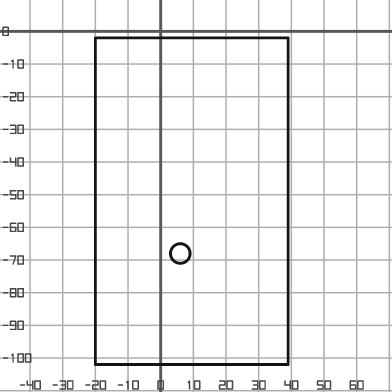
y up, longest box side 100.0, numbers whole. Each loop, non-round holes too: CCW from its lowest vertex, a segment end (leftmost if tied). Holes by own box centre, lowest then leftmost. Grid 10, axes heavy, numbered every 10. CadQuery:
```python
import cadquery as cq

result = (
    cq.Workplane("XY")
    .moveTo(-20.0, -102.0)
    .lineTo(39.0, -102.0)
    .lineTo(39.0, -2.0)
    .lineTo(-20.0, -2.0)
    .close()
    .moveTo(6.0, -68.0)
    .circle(3.0)
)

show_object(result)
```